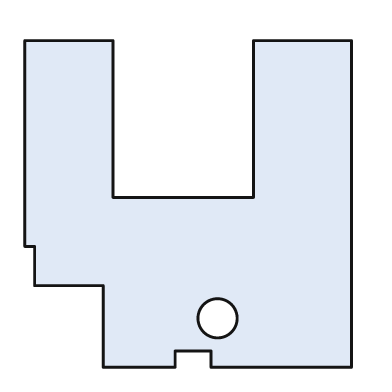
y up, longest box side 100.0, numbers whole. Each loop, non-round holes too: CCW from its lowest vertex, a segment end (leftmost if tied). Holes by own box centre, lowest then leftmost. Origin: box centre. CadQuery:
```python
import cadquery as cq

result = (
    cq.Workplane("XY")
    .moveTo(-26.0, -50.0)
    .lineTo(-4.0, -50.0)
    .lineTo(-4.0, -45.0)
    .lineTo(7.0, -45.0)
    .lineTo(7.0, -50.0)
    .lineTo(50.0, -50.0)
    .lineTo(50.0, 50.0)
    .lineTo(20.0, 50.0)
    .lineTo(20.0, 2.0)
    .lineTo(-23.0, 2.0)
    .lineTo(-23.0, 50.0)
    .lineTo(-50.0, 50.0)
    .lineTo(-50.0, -13.0)
    .lineTo(-47.0, -13.0)
    .lineTo(-47.0, -25.0)
    .lineTo(-26.0, -25.0)
    .close()
    .moveTo(9.0, -35.0)
    .circle(6.0)
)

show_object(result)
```